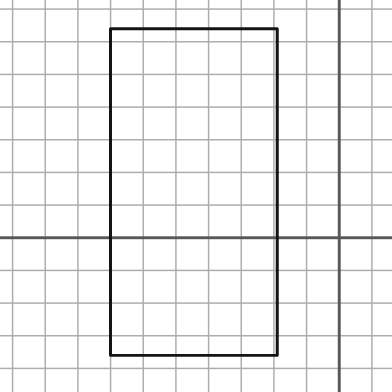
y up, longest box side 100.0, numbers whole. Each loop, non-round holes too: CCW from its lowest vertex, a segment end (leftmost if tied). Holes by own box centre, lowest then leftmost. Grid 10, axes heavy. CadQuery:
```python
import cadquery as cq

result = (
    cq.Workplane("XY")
    .moveTo(-70.0, -36.0)
    .lineTo(-19.0, -36.0)
    .lineTo(-19.0, 64.0)
    .lineTo(-70.0, 64.0)
    .close()
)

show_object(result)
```